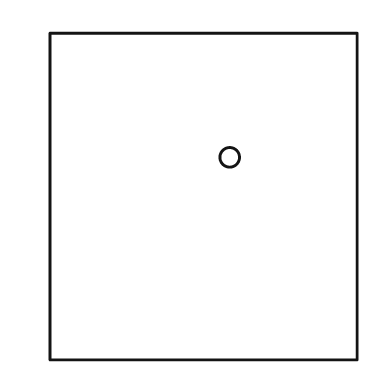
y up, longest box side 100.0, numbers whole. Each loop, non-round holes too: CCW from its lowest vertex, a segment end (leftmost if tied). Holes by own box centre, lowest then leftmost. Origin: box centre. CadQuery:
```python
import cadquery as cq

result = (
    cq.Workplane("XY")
    .moveTo(-47.0, -50.0)
    .lineTo(47.0, -50.0)
    .lineTo(47.0, 50.0)
    .lineTo(-47.0, 50.0)
    .close()
    .moveTo(8.0, 12.0)
    .circle(3.0)
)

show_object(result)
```